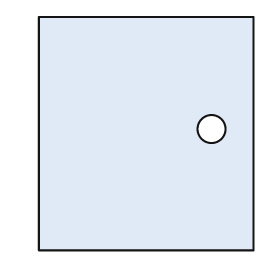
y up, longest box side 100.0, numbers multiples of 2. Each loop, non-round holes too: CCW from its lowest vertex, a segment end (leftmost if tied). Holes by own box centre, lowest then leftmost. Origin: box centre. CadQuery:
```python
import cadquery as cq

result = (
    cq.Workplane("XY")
    .moveTo(-46.0, -50.0)
    .lineTo(46.0, -50.0)
    .lineTo(46.0, 50.0)
    .lineTo(-46.0, 50.0)
    .close()
    .moveTo(28.0, 2.0)
    .circle(6.0)
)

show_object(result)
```